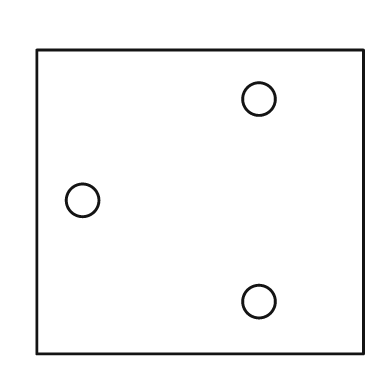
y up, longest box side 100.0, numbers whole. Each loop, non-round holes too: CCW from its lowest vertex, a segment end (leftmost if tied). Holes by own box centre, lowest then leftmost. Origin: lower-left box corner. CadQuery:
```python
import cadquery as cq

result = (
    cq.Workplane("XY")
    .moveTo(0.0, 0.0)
    .lineTo(100.0, 0.0)
    .lineTo(100.0, 93.0)
    .lineTo(0.0, 93.0)
    .close()
    .moveTo(68.0, 16.0)
    .circle(5.0)
    .moveTo(14.0, 47.0)
    .circle(5.0)
    .moveTo(68.0, 78.0)
    .circle(5.0)
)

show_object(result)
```